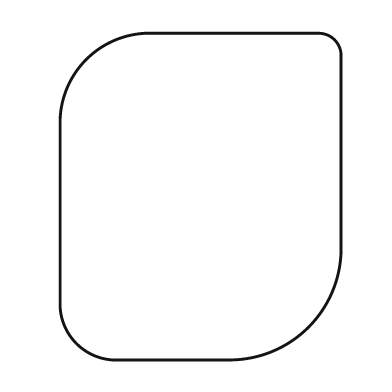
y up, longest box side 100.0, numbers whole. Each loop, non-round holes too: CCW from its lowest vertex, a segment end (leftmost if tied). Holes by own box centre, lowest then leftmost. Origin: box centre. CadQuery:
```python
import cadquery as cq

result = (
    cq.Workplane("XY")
    .moveTo(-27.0, -50.0)
    .lineTo(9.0, -50.0)
    .threePointArc((33.0, -40.0), (43.0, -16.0))
    .lineTo(43.0, 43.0)
    .threePointArc((41.0, 48.0), (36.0, 50.0))
    .lineTo(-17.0, 50.0)
    .threePointArc((-35.0, 42.0), (-43.0, 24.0))
    .lineTo(-43.0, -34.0)
    .threePointArc((-38.0, -45.0), (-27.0, -50.0))
    .close()
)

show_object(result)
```